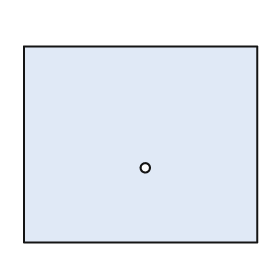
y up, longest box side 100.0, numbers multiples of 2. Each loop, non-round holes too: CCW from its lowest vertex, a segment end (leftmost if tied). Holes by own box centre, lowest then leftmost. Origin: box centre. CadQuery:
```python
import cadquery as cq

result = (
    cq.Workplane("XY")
    .moveTo(-50.0, -42.0)
    .lineTo(50.0, -42.0)
    .lineTo(50.0, 42.0)
    .lineTo(-50.0, 42.0)
    .close()
    .moveTo(2.0, -10.0)
    .circle(2.0)
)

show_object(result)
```